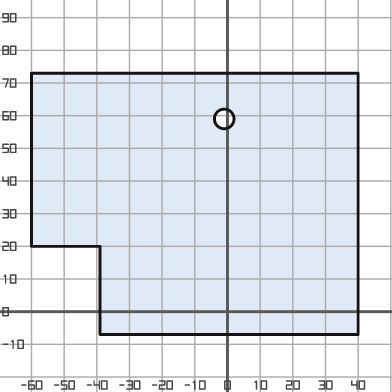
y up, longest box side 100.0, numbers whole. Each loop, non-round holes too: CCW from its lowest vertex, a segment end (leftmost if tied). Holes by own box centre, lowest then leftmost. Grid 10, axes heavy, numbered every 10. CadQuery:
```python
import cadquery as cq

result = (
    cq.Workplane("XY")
    .moveTo(-39.0, -7.0)
    .lineTo(40.0, -7.0)
    .lineTo(40.0, 73.0)
    .lineTo(-60.0, 73.0)
    .lineTo(-60.0, 20.0)
    .lineTo(-39.0, 20.0)
    .close()
    .moveTo(-1.0, 59.0)
    .circle(3.0)
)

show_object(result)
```